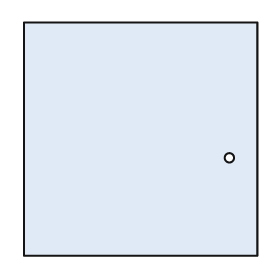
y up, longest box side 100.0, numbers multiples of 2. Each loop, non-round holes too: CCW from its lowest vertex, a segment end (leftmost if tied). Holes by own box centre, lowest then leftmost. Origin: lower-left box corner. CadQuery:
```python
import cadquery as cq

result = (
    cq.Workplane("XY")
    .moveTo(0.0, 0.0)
    .lineTo(100.0, 0.0)
    .lineTo(100.0, 100.0)
    .lineTo(0.0, 100.0)
    .close()
    .moveTo(88.0, 42.0)
    .circle(2.0)
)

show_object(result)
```